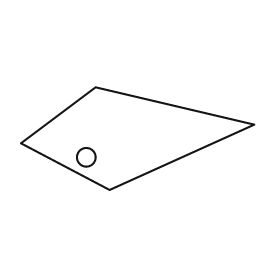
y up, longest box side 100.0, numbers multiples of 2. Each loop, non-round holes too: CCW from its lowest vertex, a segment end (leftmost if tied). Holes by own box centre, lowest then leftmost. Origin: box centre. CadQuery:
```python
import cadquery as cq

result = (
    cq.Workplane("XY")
    .moveTo(-12.0, -22.0)
    .lineTo(50.0, 6.0)
    .lineTo(-18.0, 22.0)
    .lineTo(-50.0, -2.0)
    .close()
    .moveTo(-22.0, -8.0)
    .circle(4.0)
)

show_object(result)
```